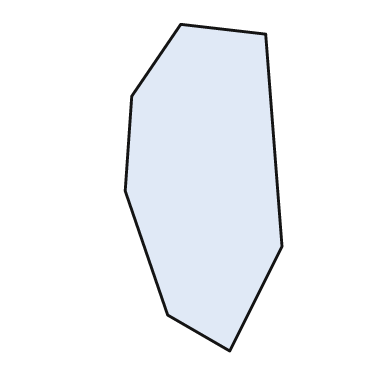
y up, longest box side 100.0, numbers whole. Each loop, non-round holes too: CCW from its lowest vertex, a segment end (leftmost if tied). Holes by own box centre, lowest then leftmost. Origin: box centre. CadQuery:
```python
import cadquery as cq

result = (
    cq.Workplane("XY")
    .moveTo(8.0, -50.0)
    .lineTo(24.0, -18.0)
    .lineTo(19.0, 47.0)
    .lineTo(-7.0, 50.0)
    .lineTo(-22.0, 28.0)
    .lineTo(-24.0, -1.0)
    .lineTo(-11.0, -39.0)
    .close()
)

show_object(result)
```